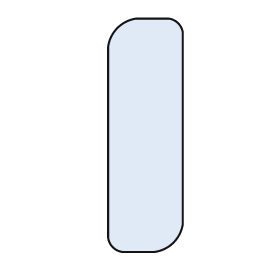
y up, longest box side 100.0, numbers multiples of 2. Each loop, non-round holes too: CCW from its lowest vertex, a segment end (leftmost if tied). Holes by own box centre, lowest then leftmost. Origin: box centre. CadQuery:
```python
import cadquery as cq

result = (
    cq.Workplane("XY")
    .moveTo(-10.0, -50.0)
    .lineTo(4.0, -50.0)
    .threePointArc((12.0, -46.0), (16.0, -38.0))
    .lineTo(16.0, 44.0)
    .threePointArc((14.0, 48.0), (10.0, 50.0))
    .lineTo(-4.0, 50.0)
    .threePointArc((-12.0, 46.0), (-16.0, 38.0))
    .lineTo(-16.0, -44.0)
    .threePointArc((-14.0, -48.0), (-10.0, -50.0))
    .close()
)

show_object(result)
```